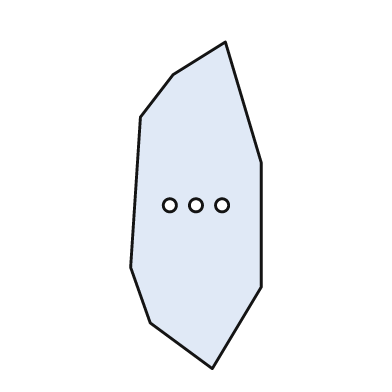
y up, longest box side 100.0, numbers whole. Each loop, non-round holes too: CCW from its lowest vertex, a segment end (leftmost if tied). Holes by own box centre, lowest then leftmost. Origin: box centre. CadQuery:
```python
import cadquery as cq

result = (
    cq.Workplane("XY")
    .moveTo(5.0, -50.0)
    .lineTo(20.0, -25.0)
    .lineTo(20.0, 13.0)
    .lineTo(9.0, 50.0)
    .lineTo(-7.0, 40.0)
    .lineTo(-17.0, 27.0)
    .lineTo(-20.0, -19.0)
    .lineTo(-14.0, -36.0)
    .close()
    .moveTo(-8.0, 0.0)
    .circle(2.0)
    .moveTo(0.0, 0.0)
    .circle(2.0)
    .moveTo(8.0, 0.0)
    .circle(2.0)
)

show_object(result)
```